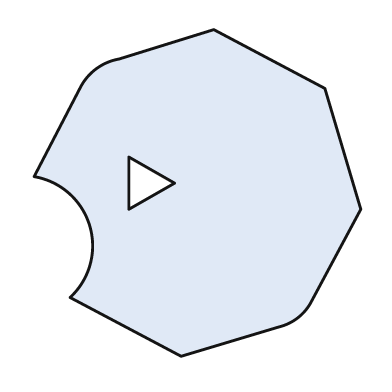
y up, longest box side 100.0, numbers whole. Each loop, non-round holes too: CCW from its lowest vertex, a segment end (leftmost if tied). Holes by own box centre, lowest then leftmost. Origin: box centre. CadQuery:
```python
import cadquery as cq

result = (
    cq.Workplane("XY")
    .moveTo(-5.0, -50.0)
    .lineTo(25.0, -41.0)
    .threePointArc((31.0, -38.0), (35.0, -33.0))
    .lineTo(50.0, -5.0)
    .lineTo(39.0, 32.0)
    .lineTo(5.0, 50.0)
    .lineTo(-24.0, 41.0)
    .threePointArc((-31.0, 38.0), (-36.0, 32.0))
    .lineTo(-50.0, 5.0)
    .threePointArc((-33.0, -10.0), (-39.0, -32.0))
    .close()
    .moveTo(-21.0, -5.0)
    .lineTo(-7.0, 3.0)
    .lineTo(-21.0, 11.0)
    .close()
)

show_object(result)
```